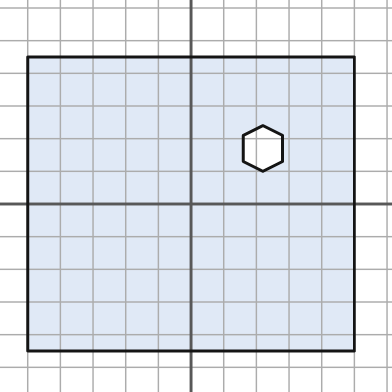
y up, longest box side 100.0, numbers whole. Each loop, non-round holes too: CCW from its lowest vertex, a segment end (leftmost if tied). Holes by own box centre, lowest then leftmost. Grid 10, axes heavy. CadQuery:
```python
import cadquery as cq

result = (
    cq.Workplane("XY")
    .moveTo(-50.0, -45.0)
    .lineTo(50.0, -45.0)
    .lineTo(50.0, 45.0)
    .lineTo(-50.0, 45.0)
    .close()
    .moveTo(22.0, 10.0)
    .lineTo(28.0, 13.0)
    .lineTo(28.0, 21.0)
    .lineTo(22.0, 24.0)
    .lineTo(16.0, 21.0)
    .lineTo(16.0, 13.0)
    .close()
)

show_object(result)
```